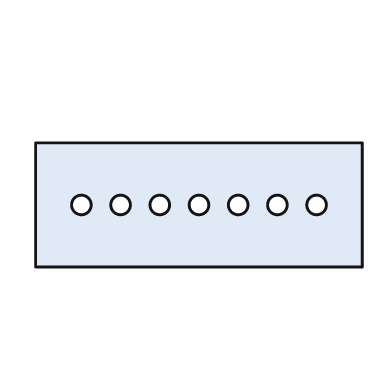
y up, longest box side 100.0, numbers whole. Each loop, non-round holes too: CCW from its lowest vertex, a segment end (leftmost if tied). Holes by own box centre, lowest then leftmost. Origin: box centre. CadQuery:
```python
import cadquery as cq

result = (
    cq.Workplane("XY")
    .moveTo(-50.0, -19.0)
    .lineTo(50.0, -19.0)
    .lineTo(50.0, 19.0)
    .lineTo(-50.0, 19.0)
    .close()
    .moveTo(-36.0, 0.0)
    .circle(3.0)
    .moveTo(-24.0, 0.0)
    .circle(3.0)
    .moveTo(-12.0, 0.0)
    .circle(3.0)
    .moveTo(0.0, 0.0)
    .circle(3.0)
    .moveTo(12.0, 0.0)
    .circle(3.0)
    .moveTo(24.0, 0.0)
    .circle(3.0)
    .moveTo(36.0, 0.0)
    .circle(3.0)
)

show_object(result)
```